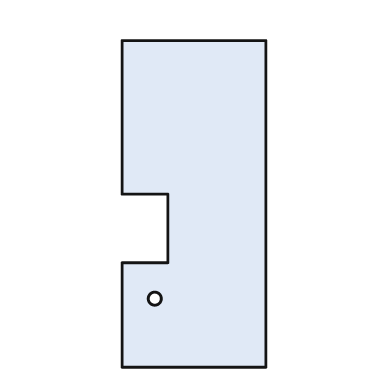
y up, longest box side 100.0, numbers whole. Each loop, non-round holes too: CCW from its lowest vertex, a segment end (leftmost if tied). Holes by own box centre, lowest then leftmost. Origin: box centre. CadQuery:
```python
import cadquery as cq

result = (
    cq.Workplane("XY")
    .moveTo(-22.0, -50.0)
    .lineTo(22.0, -50.0)
    .lineTo(22.0, 50.0)
    .lineTo(-22.0, 50.0)
    .lineTo(-22.0, 3.0)
    .lineTo(-8.0, 3.0)
    .lineTo(-8.0, -18.0)
    .lineTo(-22.0, -18.0)
    .close()
    .moveTo(-12.0, -29.0)
    .circle(2.0)
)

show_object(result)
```